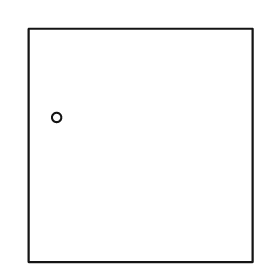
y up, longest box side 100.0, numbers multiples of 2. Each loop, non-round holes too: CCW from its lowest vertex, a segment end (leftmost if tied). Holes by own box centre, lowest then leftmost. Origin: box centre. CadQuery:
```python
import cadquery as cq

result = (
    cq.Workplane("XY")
    .moveTo(-48.0, -50.0)
    .lineTo(48.0, -50.0)
    .lineTo(48.0, 50.0)
    .lineTo(-48.0, 50.0)
    .close()
    .moveTo(-36.0, 12.0)
    .circle(2.0)
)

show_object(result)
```